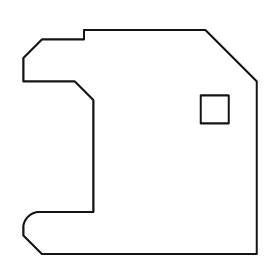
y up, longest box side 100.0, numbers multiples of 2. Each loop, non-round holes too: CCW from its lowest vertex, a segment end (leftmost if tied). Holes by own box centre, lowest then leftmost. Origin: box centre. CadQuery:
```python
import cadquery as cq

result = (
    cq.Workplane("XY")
    .moveTo(-42.0, -48.0)
    .lineTo(50.0, -48.0)
    .lineTo(50.0, 26.0)
    .lineTo(28.0, 48.0)
    .lineTo(-24.0, 48.0)
    .lineTo(-24.0, 44.0)
    .lineTo(-42.0, 44.0)
    .lineTo(-50.0, 36.0)
    .lineTo(-50.0, 26.0)
    .lineTo(-28.0, 26.0)
    .lineTo(-20.0, 18.0)
    .lineTo(-20.0, -30.0)
    .lineTo(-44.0, -30.0)
    .threePointArc((-48.0, -32.0), (-50.0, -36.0))
    .lineTo(-50.0, -40.0)
    .close()
    .moveTo(26.0, 8.0)
    .lineTo(38.0, 8.0)
    .lineTo(38.0, 20.0)
    .lineTo(26.0, 20.0)
    .close()
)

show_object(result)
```